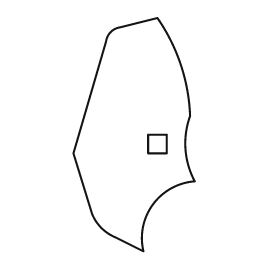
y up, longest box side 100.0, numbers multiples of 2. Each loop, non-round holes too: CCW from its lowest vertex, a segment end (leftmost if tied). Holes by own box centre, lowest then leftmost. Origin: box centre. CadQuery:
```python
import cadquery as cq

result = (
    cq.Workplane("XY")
    .moveTo(4.0, -50.0)
    .threePointArc((8.0, -30.0), (26.0, -20.0))
    .threePointArc((22.0, -6.0), (24.0, 8.0))
    .threePointArc((20.0, 30.0), (10.0, 50.0))
    .lineTo(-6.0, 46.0)
    .threePointArc((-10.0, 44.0), (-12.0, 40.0))
    .lineTo(-26.0, -8.0)
    .lineTo(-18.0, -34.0)
    .threePointArc((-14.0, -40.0), (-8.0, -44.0))
    .close()
    .moveTo(6.0, -8.0)
    .lineTo(14.0, -8.0)
    .lineTo(14.0, 0.0)
    .lineTo(6.0, 0.0)
    .close()
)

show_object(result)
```